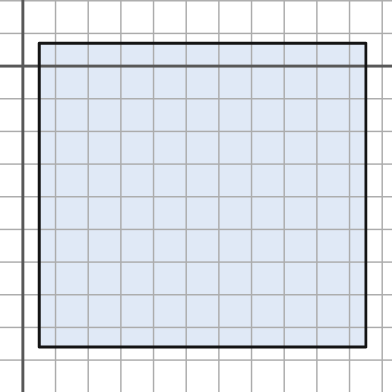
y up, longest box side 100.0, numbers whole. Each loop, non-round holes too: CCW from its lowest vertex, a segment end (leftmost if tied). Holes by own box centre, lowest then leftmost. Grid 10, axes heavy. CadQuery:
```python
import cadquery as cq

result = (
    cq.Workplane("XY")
    .moveTo(5.0, -86.0)
    .lineTo(105.0, -86.0)
    .lineTo(105.0, 7.0)
    .lineTo(5.0, 7.0)
    .close()
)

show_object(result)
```